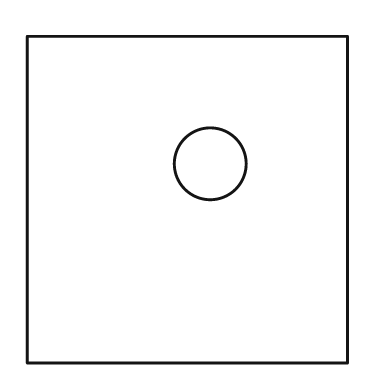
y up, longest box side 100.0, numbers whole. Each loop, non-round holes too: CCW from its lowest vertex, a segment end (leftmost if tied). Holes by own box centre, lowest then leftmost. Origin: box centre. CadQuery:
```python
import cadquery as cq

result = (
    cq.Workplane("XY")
    .moveTo(-49.0, -50.0)
    .lineTo(49.0, -50.0)
    .lineTo(49.0, 50.0)
    .lineTo(-49.0, 50.0)
    .close()
    .moveTo(7.0, 11.0)
    .circle(11.0)
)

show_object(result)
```